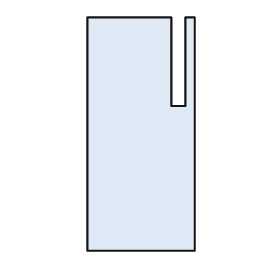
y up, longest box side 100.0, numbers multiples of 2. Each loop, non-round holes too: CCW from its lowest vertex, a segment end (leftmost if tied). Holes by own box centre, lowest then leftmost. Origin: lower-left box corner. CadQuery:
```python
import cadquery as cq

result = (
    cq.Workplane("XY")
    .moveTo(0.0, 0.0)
    .lineTo(46.0, 0.0)
    .lineTo(46.0, 100.0)
    .lineTo(42.0, 100.0)
    .lineTo(42.0, 62.0)
    .lineTo(36.0, 62.0)
    .lineTo(36.0, 100.0)
    .lineTo(0.0, 100.0)
    .close()
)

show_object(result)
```